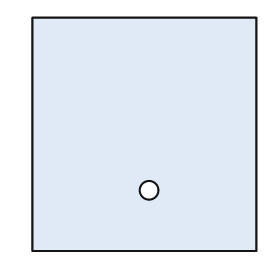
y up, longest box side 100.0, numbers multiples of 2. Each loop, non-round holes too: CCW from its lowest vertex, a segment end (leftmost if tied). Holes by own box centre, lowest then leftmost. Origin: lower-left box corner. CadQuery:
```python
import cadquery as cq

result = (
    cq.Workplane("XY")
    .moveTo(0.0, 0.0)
    .lineTo(96.0, 0.0)
    .lineTo(96.0, 100.0)
    .lineTo(0.0, 100.0)
    .close()
    .moveTo(50.0, 26.0)
    .circle(4.0)
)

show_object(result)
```